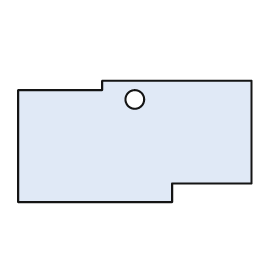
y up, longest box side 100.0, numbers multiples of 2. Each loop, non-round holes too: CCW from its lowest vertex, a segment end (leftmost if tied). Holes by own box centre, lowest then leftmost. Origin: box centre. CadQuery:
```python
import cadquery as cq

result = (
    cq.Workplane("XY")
    .moveTo(-50.0, -26.0)
    .lineTo(16.0, -26.0)
    .lineTo(16.0, -18.0)
    .lineTo(50.0, -18.0)
    .lineTo(50.0, 26.0)
    .lineTo(-14.0, 26.0)
    .lineTo(-14.0, 22.0)
    .lineTo(-50.0, 22.0)
    .close()
    .moveTo(0.0, 18.0)
    .circle(4.0)
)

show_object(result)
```